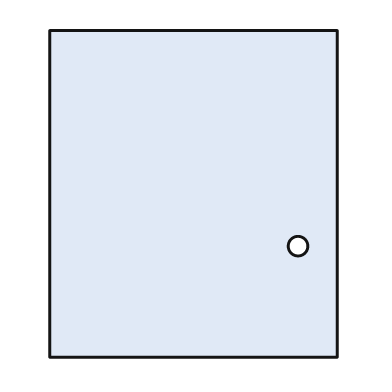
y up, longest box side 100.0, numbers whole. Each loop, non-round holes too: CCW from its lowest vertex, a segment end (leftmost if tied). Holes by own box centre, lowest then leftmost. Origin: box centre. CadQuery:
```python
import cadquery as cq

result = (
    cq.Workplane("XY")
    .moveTo(-44.0, -50.0)
    .lineTo(44.0, -50.0)
    .lineTo(44.0, 50.0)
    .lineTo(-44.0, 50.0)
    .close()
    .moveTo(32.0, -16.0)
    .circle(3.0)
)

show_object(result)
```